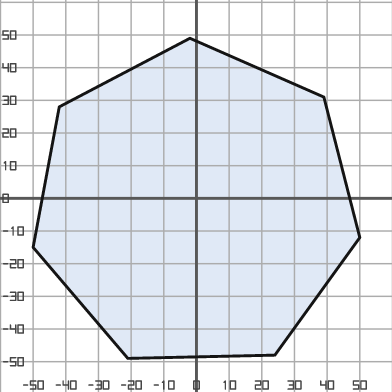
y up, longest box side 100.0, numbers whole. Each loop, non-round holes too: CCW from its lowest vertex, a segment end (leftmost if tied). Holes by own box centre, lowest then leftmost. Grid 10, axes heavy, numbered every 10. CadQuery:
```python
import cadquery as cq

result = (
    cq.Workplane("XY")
    .moveTo(-21.0, -49.0)
    .lineTo(24.0, -48.0)
    .lineTo(50.0, -12.0)
    .lineTo(39.0, 31.0)
    .lineTo(-2.0, 49.0)
    .lineTo(-42.0, 28.0)
    .lineTo(-50.0, -15.0)
    .close()
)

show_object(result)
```